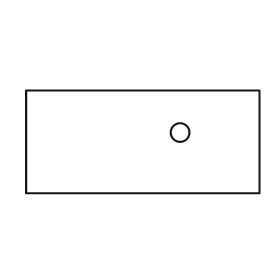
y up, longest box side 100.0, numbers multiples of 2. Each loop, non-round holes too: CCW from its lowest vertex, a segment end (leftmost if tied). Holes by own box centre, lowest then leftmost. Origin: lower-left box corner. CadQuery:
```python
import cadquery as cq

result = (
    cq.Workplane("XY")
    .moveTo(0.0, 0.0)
    .lineTo(100.0, 0.0)
    .lineTo(100.0, 44.0)
    .lineTo(0.0, 44.0)
    .close()
    .moveTo(66.0, 26.0)
    .circle(4.0)
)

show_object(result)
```